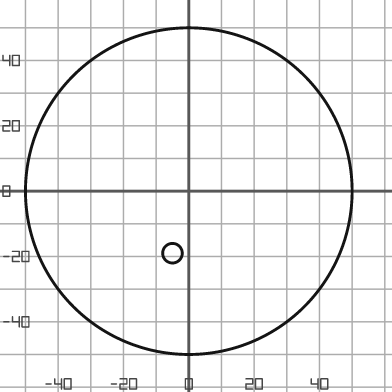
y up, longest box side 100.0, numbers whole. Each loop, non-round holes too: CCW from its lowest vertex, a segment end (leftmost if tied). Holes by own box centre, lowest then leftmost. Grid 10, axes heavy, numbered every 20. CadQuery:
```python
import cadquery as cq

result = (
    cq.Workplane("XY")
    .moveTo(0.0, 0.0)
    .circle(50.0)
    .moveTo(-5.0, -19.0)
    .circle(3.0)
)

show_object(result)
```